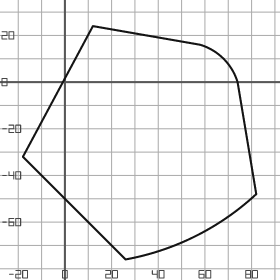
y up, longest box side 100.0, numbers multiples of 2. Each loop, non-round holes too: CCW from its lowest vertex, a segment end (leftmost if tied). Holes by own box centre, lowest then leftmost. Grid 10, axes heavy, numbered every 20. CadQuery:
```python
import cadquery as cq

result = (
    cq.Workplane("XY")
    .moveTo(26.0, -76.0)
    .threePointArc((56.0, -66.0), (82.0, -48.0))
    .lineTo(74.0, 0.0)
    .threePointArc((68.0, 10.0), (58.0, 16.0))
    .lineTo(12.0, 24.0)
    .lineTo(-18.0, -32.0)
    .close()
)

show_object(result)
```